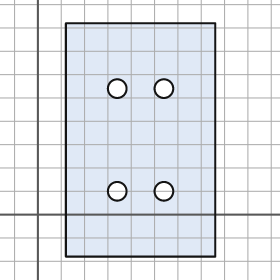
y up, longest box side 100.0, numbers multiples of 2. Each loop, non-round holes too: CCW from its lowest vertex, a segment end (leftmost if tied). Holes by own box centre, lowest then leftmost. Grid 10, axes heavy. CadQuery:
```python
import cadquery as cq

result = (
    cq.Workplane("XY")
    .moveTo(12.0, -18.0)
    .lineTo(76.0, -18.0)
    .lineTo(76.0, 82.0)
    .lineTo(12.0, 82.0)
    .close()
    .moveTo(34.0, 10.0)
    .circle(4.0)
    .moveTo(54.0, 10.0)
    .circle(4.0)
    .moveTo(34.0, 54.0)
    .circle(4.0)
    .moveTo(54.0, 54.0)
    .circle(4.0)
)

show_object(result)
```